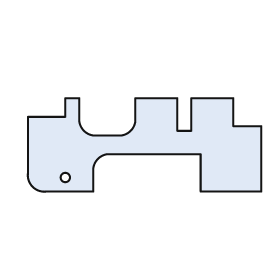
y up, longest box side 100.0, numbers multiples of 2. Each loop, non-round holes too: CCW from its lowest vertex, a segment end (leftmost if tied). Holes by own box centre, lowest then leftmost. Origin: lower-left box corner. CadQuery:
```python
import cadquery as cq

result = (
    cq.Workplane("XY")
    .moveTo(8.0, 0.0)
    .lineTo(28.0, 0.0)
    .lineTo(28.0, 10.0)
    .threePointArc((30.0, 14.0), (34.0, 16.0))
    .lineTo(74.0, 16.0)
    .lineTo(74.0, 0.0)
    .lineTo(100.0, 0.0)
    .lineTo(100.0, 28.0)
    .lineTo(88.0, 28.0)
    .lineTo(88.0, 40.0)
    .lineTo(70.0, 40.0)
    .lineTo(70.0, 26.0)
    .lineTo(64.0, 26.0)
    .lineTo(64.0, 40.0)
    .lineTo(46.0, 40.0)
    .lineTo(46.0, 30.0)
    .threePointArc((44.0, 26.0), (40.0, 24.0))
    .lineTo(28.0, 24.0)
    .threePointArc((24.0, 26.0), (22.0, 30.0))
    .lineTo(22.0, 40.0)
    .lineTo(16.0, 40.0)
    .lineTo(16.0, 32.0)
    .lineTo(0.0, 32.0)
    .lineTo(0.0, 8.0)
    .threePointArc((2.0, 2.0), (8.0, 0.0))
    .close()
    .moveTo(16.0, 6.0)
    .circle(2.0)
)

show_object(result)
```